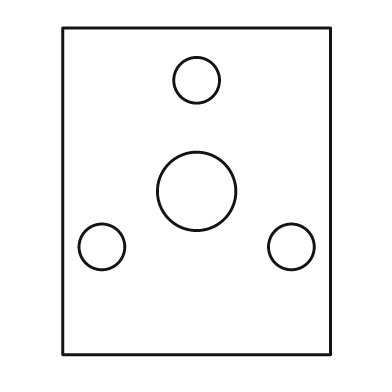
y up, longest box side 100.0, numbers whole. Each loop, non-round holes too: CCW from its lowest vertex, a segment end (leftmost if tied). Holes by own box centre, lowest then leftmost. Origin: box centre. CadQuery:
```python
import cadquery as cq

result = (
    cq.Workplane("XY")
    .moveTo(-41.0, -50.0)
    .lineTo(41.0, -50.0)
    .lineTo(41.0, 50.0)
    .lineTo(-41.0, 50.0)
    .close()
    .moveTo(-29.0, -17.0)
    .circle(7.0)
    .moveTo(29.0, -17.0)
    .circle(7.0)
    .moveTo(0.0, 0.0)
    .circle(12.0)
    .moveTo(0.0, 34.0)
    .circle(7.0)
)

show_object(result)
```